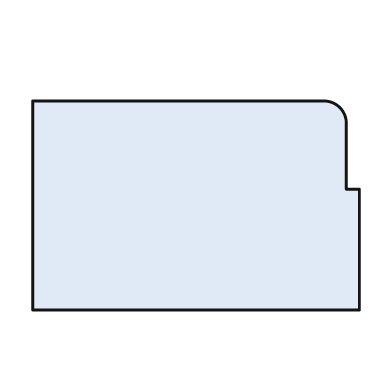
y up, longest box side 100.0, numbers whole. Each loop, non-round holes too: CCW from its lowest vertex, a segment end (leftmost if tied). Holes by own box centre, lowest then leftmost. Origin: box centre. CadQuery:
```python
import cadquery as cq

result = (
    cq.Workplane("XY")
    .moveTo(-50.0, -32.0)
    .lineTo(50.0, -32.0)
    .lineTo(50.0, 5.0)
    .lineTo(46.0, 5.0)
    .lineTo(46.0, 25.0)
    .threePointArc((44.0, 30.0), (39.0, 32.0))
    .lineTo(-50.0, 32.0)
    .close()
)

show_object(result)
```